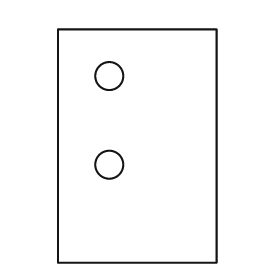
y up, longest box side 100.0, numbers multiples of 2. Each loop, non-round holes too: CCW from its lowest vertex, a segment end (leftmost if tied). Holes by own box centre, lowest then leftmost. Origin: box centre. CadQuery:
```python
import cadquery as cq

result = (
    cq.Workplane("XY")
    .moveTo(-34.0, -50.0)
    .lineTo(34.0, -50.0)
    .lineTo(34.0, 50.0)
    .lineTo(-34.0, 50.0)
    .close()
    .moveTo(-12.0, -8.0)
    .circle(6.0)
    .moveTo(-12.0, 30.0)
    .circle(6.0)
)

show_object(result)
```